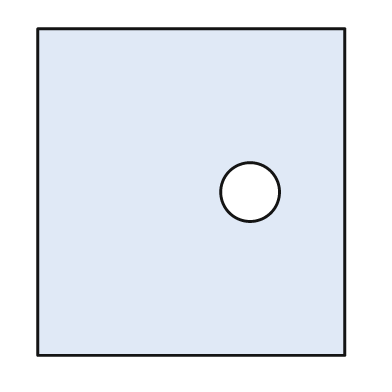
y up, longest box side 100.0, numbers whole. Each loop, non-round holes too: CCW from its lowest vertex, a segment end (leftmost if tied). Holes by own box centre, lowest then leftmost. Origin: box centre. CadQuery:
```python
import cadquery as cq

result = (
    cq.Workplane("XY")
    .moveTo(-47.0, -50.0)
    .lineTo(47.0, -50.0)
    .lineTo(47.0, 50.0)
    .lineTo(-47.0, 50.0)
    .close()
    .moveTo(18.0, 0.0)
    .circle(9.0)
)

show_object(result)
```